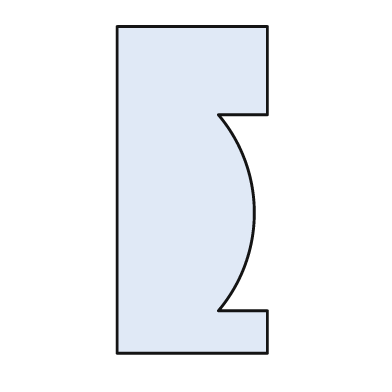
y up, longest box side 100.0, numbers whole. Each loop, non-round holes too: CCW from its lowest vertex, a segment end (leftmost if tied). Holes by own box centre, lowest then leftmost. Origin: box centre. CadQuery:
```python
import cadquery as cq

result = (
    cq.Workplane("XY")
    .moveTo(-23.0, -50.0)
    .lineTo(23.0, -50.0)
    .lineTo(23.0, -37.0)
    .lineTo(8.0, -37.0)
    .threePointArc((19.0, -7.0), (8.0, 23.0))
    .lineTo(23.0, 23.0)
    .lineTo(23.0, 50.0)
    .lineTo(-23.0, 50.0)
    .close()
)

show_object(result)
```